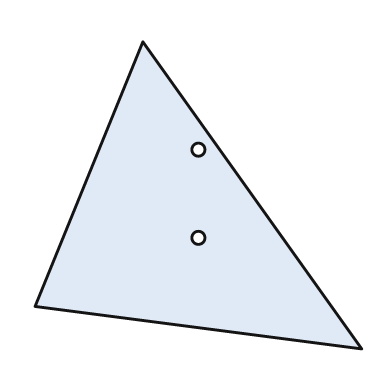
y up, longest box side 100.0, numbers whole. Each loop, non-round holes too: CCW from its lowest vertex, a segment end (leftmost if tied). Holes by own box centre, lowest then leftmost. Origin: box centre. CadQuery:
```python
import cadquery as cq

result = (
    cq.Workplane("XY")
    .moveTo(50.0, -47.0)
    .lineTo(-17.0, 47.0)
    .lineTo(-50.0, -34.0)
    .close()
    .moveTo(0.0, -13.0)
    .circle(2.0)
    .moveTo(0.0, 14.0)
    .circle(2.0)
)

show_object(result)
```